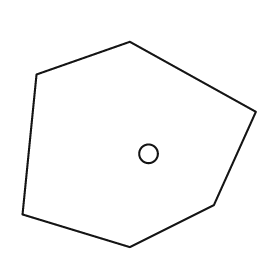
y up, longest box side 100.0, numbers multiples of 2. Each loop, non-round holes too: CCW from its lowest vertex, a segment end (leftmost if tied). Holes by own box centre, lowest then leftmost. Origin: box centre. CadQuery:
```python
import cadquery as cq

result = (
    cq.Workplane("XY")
    .moveTo(-4.0, -44.0)
    .lineTo(32.0, -26.0)
    .lineTo(50.0, 14.0)
    .lineTo(-4.0, 44.0)
    .lineTo(-44.0, 30.0)
    .lineTo(-50.0, -30.0)
    .close()
    .moveTo(4.0, -4.0)
    .circle(4.0)
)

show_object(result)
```